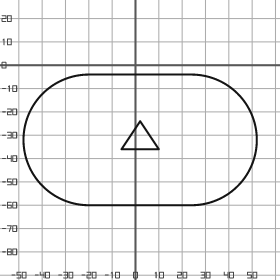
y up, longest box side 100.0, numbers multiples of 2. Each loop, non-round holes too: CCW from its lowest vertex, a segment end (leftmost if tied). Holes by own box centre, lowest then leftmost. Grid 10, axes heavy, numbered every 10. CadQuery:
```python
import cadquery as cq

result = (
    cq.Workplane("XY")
    .moveTo(-20.0, -60.0)
    .lineTo(24.0, -60.0)
    .threePointArc((52.0, -32.0), (24.0, -4.0))
    .lineTo(-20.0, -4.0)
    .threePointArc((-48.0, -32.0), (-20.0, -60.0))
    .close()
    .moveTo(-6.0, -36.0)
    .lineTo(10.0, -36.0)
    .lineTo(2.0, -24.0)
    .close()
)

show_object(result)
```